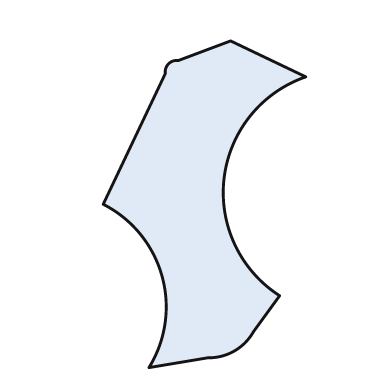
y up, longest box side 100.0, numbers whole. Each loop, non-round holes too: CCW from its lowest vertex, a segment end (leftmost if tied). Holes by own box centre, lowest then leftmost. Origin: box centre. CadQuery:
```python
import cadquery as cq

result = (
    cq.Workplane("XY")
    .moveTo(-17.0, -50.0)
    .lineTo(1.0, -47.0)
    .threePointArc((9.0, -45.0), (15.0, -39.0))
    .lineTo(23.0, -28.0)
    .threePointArc((6.0, 8.0), (31.0, 39.0))
    .lineTo(8.0, 50.0)
    .lineTo(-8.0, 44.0)
    .threePointArc((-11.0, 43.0), (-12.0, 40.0))
    .lineTo(-31.0, 0.0)
    .threePointArc((-13.0, -22.0), (-17.0, -50.0))
    .close()
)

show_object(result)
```